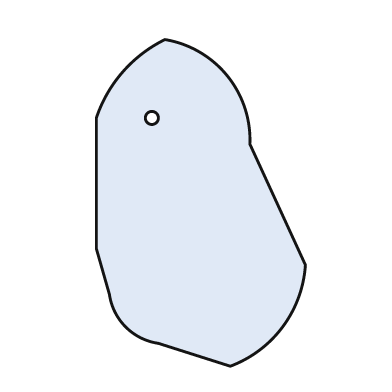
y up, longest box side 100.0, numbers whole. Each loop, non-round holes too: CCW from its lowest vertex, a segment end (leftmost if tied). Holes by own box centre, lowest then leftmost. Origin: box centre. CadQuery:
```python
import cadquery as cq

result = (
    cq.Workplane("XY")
    .moveTo(9.0, -50.0)
    .threePointArc((25.0, -38.0), (32.0, -19.0))
    .lineTo(15.0, 18.0)
    .threePointArc((8.0, 39.0), (-11.0, 50.0))
    .threePointArc((-24.0, 40.0), (-32.0, 26.0))
    .lineTo(-32.0, -14.0)
    .lineTo(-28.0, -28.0)
    .threePointArc((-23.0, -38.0), (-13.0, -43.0))
    .close()
    .moveTo(-15.0, 26.0)
    .circle(2.0)
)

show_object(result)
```